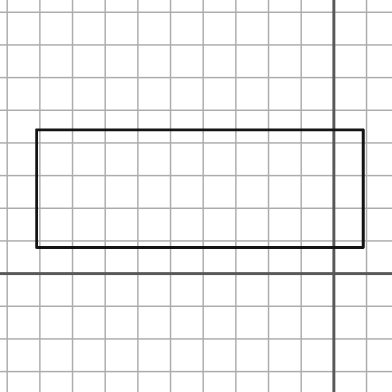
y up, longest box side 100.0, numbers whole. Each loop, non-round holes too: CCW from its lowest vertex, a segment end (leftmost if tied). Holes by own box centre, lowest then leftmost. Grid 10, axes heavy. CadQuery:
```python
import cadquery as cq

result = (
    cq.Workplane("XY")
    .moveTo(-91.0, 8.0)
    .lineTo(9.0, 8.0)
    .lineTo(9.0, 44.0)
    .lineTo(-91.0, 44.0)
    .close()
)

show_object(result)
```